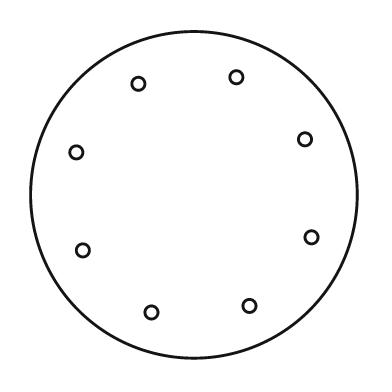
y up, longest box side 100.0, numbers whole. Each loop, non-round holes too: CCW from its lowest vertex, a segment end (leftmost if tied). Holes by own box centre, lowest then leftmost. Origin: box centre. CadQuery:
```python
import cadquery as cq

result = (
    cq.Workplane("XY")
    .moveTo(0.0, 0.0)
    .circle(50.0)
    .moveTo(-13.0, -36.0)
    .circle(2.0)
    .moveTo(17.0, -34.0)
    .circle(2.0)
    .moveTo(-34.0, -17.0)
    .circle(2.0)
    .moveTo(36.0, -13.0)
    .circle(2.0)
    .moveTo(-36.0, 13.0)
    .circle(2.0)
    .moveTo(34.0, 17.0)
    .circle(2.0)
    .moveTo(-17.0, 34.0)
    .circle(2.0)
    .moveTo(13.0, 36.0)
    .circle(2.0)
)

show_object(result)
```